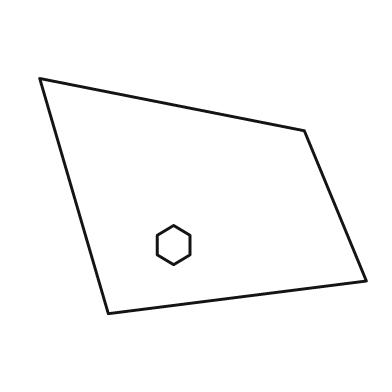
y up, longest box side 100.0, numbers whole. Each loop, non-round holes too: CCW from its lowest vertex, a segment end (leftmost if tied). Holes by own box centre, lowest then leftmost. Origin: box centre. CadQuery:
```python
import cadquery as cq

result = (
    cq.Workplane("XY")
    .moveTo(-29.0, -36.0)
    .lineTo(50.0, -26.0)
    .lineTo(31.0, 20.0)
    .lineTo(-50.0, 36.0)
    .close()
    .moveTo(-9.0, -21.0)
    .lineTo(-4.0, -18.0)
    .lineTo(-4.0, -12.0)
    .lineTo(-9.0, -9.0)
    .lineTo(-14.0, -12.0)
    .lineTo(-14.0, -18.0)
    .close()
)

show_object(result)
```